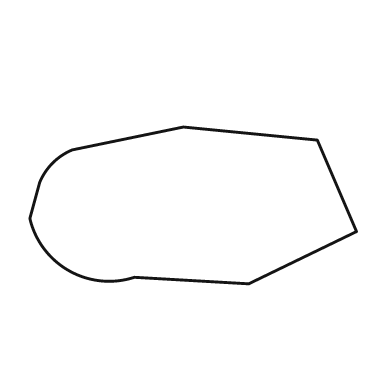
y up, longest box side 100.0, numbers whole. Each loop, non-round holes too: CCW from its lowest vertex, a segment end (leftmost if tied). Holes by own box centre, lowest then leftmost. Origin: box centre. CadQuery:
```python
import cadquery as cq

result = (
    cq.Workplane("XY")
    .moveTo(17.0, -24.0)
    .lineTo(50.0, -8.0)
    .lineTo(38.0, 20.0)
    .lineTo(-3.0, 24.0)
    .lineTo(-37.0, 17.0)
    .threePointArc((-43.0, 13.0), (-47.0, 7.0))
    .lineTo(-50.0, -4.0)
    .threePointArc((-38.0, -20.0), (-18.0, -22.0))
    .close()
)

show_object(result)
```